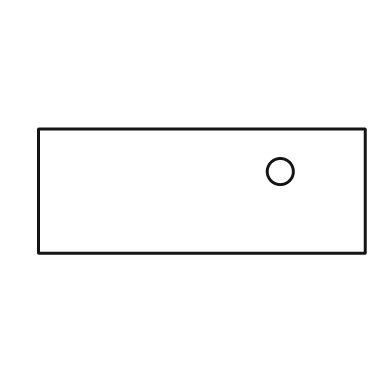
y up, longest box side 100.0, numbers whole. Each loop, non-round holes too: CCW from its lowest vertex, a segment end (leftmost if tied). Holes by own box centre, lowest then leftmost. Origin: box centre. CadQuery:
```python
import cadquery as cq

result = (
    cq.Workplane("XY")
    .moveTo(-50.0, -19.0)
    .lineTo(50.0, -19.0)
    .lineTo(50.0, 19.0)
    .lineTo(-50.0, 19.0)
    .close()
    .moveTo(24.0, 6.0)
    .circle(4.0)
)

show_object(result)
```